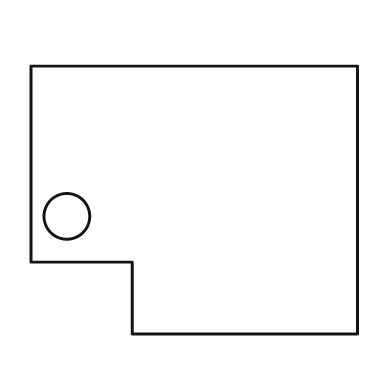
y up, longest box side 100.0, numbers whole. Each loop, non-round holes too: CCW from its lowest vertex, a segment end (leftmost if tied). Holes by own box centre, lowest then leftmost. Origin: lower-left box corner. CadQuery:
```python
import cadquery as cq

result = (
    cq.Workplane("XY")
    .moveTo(31.0, 0.0)
    .lineTo(100.0, 0.0)
    .lineTo(100.0, 82.0)
    .lineTo(0.0, 82.0)
    .lineTo(0.0, 22.0)
    .lineTo(31.0, 22.0)
    .close()
    .moveTo(11.0, 36.0)
    .circle(7.0)
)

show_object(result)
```